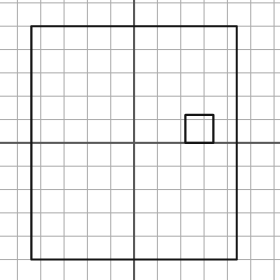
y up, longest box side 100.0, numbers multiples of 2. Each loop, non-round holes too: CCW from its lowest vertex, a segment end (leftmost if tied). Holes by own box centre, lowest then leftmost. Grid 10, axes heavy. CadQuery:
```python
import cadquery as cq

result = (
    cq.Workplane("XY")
    .moveTo(-44.0, -50.0)
    .lineTo(44.0, -50.0)
    .lineTo(44.0, 50.0)
    .lineTo(-44.0, 50.0)
    .close()
    .moveTo(22.0, 0.0)
    .lineTo(34.0, 0.0)
    .lineTo(34.0, 12.0)
    .lineTo(22.0, 12.0)
    .close()
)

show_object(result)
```